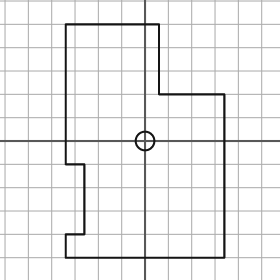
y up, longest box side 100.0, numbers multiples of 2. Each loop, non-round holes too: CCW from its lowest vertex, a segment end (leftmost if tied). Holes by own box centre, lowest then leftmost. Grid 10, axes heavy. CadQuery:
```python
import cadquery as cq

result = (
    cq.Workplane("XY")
    .moveTo(-34.0, -50.0)
    .lineTo(34.0, -50.0)
    .lineTo(34.0, 20.0)
    .lineTo(6.0, 20.0)
    .lineTo(6.0, 50.0)
    .lineTo(-34.0, 50.0)
    .lineTo(-34.0, -10.0)
    .lineTo(-26.0, -10.0)
    .lineTo(-26.0, -40.0)
    .lineTo(-34.0, -40.0)
    .close()
    .moveTo(0.0, 0.0)
    .circle(4.0)
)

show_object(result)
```